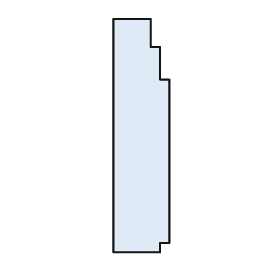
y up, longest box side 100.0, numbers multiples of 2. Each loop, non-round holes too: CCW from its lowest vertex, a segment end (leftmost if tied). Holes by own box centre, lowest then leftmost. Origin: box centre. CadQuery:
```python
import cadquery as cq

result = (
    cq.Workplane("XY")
    .moveTo(-12.0, -50.0)
    .lineTo(8.0, -50.0)
    .lineTo(8.0, -46.0)
    .lineTo(12.0, -46.0)
    .lineTo(12.0, 24.0)
    .lineTo(8.0, 24.0)
    .lineTo(8.0, 38.0)
    .lineTo(4.0, 38.0)
    .lineTo(4.0, 50.0)
    .lineTo(-12.0, 50.0)
    .close()
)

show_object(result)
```